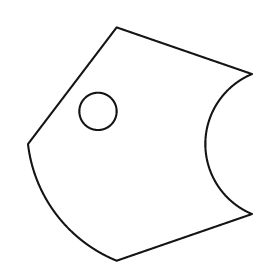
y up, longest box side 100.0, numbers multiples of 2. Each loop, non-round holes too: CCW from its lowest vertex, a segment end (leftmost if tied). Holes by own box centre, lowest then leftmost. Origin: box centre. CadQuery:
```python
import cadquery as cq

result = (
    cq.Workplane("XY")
    .moveTo(-10.0, -50.0)
    .lineTo(48.0, -30.0)
    .threePointArc((28.0, 0.0), (48.0, 30.0))
    .lineTo(-10.0, 50.0)
    .lineTo(-48.0, 0.0)
    .threePointArc((-36.0, -30.0), (-10.0, -50.0))
    .close()
    .moveTo(-18.0, 14.0)
    .circle(8.0)
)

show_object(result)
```